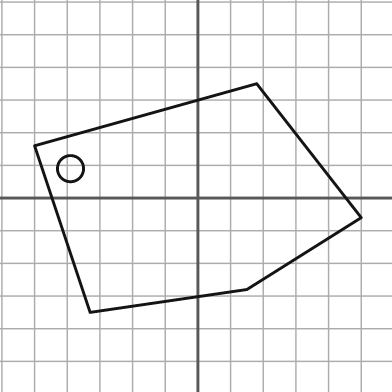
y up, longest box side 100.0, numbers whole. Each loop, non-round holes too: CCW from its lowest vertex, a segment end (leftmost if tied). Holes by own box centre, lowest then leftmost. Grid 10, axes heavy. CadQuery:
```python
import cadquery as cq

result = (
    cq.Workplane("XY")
    .moveTo(-33.0, -35.0)
    .lineTo(15.0, -28.0)
    .lineTo(50.0, -6.0)
    .lineTo(18.0, 35.0)
    .lineTo(-50.0, 16.0)
    .close()
    .moveTo(-39.0, 9.0)
    .circle(4.0)
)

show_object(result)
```